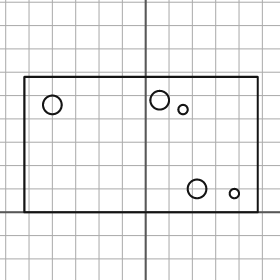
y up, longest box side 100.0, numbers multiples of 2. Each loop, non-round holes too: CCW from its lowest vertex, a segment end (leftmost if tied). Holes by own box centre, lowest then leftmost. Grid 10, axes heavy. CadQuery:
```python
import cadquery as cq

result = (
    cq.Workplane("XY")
    .moveTo(-52.0, 0.0)
    .lineTo(48.0, 0.0)
    .lineTo(48.0, 58.0)
    .lineTo(-52.0, 58.0)
    .close()
    .moveTo(38.0, 8.0)
    .circle(2.0)
    .moveTo(22.0, 10.0)
    .circle(4.0)
    .moveTo(16.0, 44.0)
    .circle(2.0)
    .moveTo(-40.0, 46.0)
    .circle(4.0)
    .moveTo(6.0, 48.0)
    .circle(4.0)
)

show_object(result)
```